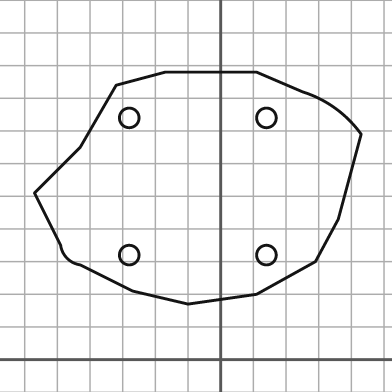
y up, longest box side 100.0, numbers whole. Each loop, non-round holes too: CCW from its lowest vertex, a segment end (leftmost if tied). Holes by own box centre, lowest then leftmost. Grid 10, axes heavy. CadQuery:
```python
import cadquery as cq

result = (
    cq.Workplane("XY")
    .moveTo(-10.0, 17.0)
    .lineTo(11.0, 20.0)
    .lineTo(29.0, 30.0)
    .lineTo(36.0, 43.0)
    .lineTo(43.0, 69.0)
    .threePointArc((35.0, 77.0), (25.0, 82.0))
    .lineTo(11.0, 88.0)
    .lineTo(-17.0, 88.0)
    .lineTo(-32.0, 84.0)
    .lineTo(-43.0, 65.0)
    .lineTo(-57.0, 51.0)
    .lineTo(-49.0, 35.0)
    .threePointArc((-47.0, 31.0), (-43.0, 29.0))
    .lineTo(-27.0, 21.0)
    .close()
    .moveTo(-28.0, 32.0)
    .circle(3.0)
    .moveTo(14.0, 32.0)
    .circle(3.0)
    .moveTo(-28.0, 74.0)
    .circle(3.0)
    .moveTo(14.0, 74.0)
    .circle(3.0)
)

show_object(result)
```